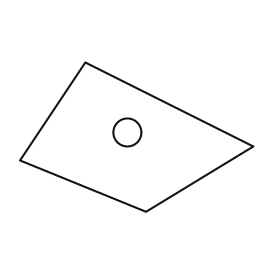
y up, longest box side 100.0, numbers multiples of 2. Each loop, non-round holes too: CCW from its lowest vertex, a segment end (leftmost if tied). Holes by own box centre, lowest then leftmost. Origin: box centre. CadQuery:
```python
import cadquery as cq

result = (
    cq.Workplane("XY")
    .moveTo(4.0, -32.0)
    .lineTo(50.0, -4.0)
    .lineTo(-22.0, 32.0)
    .lineTo(-50.0, -10.0)
    .close()
    .moveTo(-4.0, 2.0)
    .circle(6.0)
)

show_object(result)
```